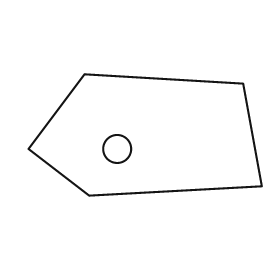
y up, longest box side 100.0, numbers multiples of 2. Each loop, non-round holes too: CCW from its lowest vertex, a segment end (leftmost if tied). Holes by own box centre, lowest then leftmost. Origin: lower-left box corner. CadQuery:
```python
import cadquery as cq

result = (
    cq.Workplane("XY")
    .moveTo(26.0, 0.0)
    .lineTo(100.0, 4.0)
    .lineTo(92.0, 48.0)
    .lineTo(24.0, 52.0)
    .lineTo(0.0, 20.0)
    .close()
    .moveTo(38.0, 20.0)
    .circle(6.0)
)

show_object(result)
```